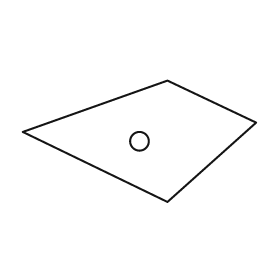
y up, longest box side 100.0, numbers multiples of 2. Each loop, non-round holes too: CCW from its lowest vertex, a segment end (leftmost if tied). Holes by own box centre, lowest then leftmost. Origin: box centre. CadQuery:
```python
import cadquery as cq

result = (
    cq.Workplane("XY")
    .moveTo(12.0, -26.0)
    .lineTo(50.0, 8.0)
    .lineTo(12.0, 26.0)
    .lineTo(-50.0, 4.0)
    .close()
    .moveTo(0.0, 0.0)
    .circle(4.0)
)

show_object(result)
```